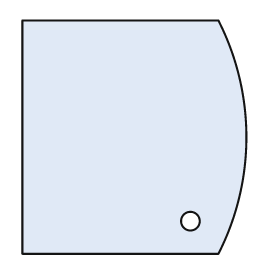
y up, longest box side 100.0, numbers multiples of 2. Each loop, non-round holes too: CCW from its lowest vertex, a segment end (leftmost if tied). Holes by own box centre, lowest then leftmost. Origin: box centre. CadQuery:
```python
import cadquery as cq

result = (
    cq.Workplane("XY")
    .moveTo(-48.0, -50.0)
    .lineTo(36.0, -50.0)
    .threePointArc((48.0, 0.0), (36.0, 50.0))
    .lineTo(-48.0, 50.0)
    .close()
    .moveTo(24.0, -36.0)
    .circle(4.0)
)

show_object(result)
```